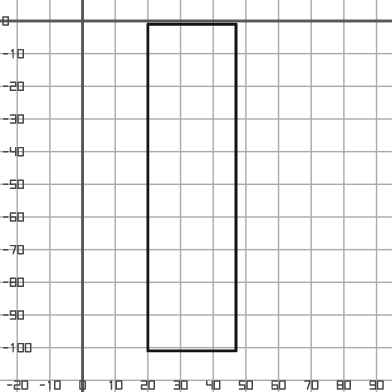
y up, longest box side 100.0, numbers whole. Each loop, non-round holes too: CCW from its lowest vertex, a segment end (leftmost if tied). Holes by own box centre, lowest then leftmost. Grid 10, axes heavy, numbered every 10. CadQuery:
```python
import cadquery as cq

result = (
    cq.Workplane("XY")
    .moveTo(20.0, -101.0)
    .lineTo(47.0, -101.0)
    .lineTo(47.0, -1.0)
    .lineTo(20.0, -1.0)
    .close()
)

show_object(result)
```